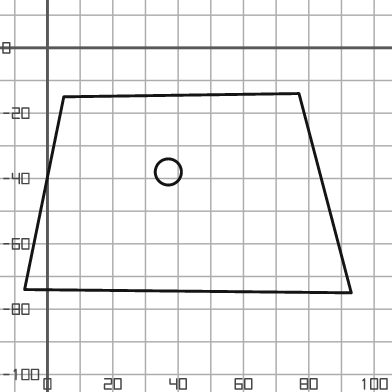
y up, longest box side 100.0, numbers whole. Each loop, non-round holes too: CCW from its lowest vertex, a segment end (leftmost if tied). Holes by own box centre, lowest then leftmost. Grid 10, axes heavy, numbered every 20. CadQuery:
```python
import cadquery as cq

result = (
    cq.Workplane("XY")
    .moveTo(93.0, -75.0)
    .lineTo(77.0, -14.0)
    .lineTo(5.0, -15.0)
    .lineTo(-7.0, -74.0)
    .close()
    .moveTo(37.0, -38.0)
    .circle(4.0)
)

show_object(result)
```